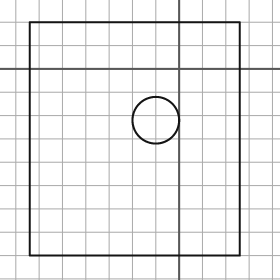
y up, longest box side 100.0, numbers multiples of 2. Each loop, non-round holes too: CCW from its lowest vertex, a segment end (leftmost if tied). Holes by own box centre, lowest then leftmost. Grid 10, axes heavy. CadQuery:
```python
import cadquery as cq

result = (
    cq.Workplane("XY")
    .moveTo(-64.0, -80.0)
    .lineTo(26.0, -80.0)
    .lineTo(26.0, 20.0)
    .lineTo(-64.0, 20.0)
    .close()
    .moveTo(-10.0, -22.0)
    .circle(10.0)
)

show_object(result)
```